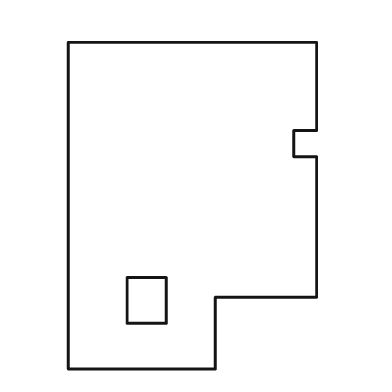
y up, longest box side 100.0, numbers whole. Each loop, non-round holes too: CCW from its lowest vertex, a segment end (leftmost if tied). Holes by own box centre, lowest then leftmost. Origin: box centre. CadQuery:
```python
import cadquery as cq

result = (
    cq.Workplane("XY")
    .moveTo(-38.0, -50.0)
    .lineTo(7.0, -50.0)
    .lineTo(7.0, -28.0)
    .lineTo(38.0, -28.0)
    .lineTo(38.0, 15.0)
    .lineTo(31.0, 15.0)
    .lineTo(31.0, 23.0)
    .lineTo(38.0, 23.0)
    .lineTo(38.0, 50.0)
    .lineTo(-38.0, 50.0)
    .close()
    .moveTo(-20.0, -36.0)
    .lineTo(-8.0, -36.0)
    .lineTo(-8.0, -22.0)
    .lineTo(-20.0, -22.0)
    .close()
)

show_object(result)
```